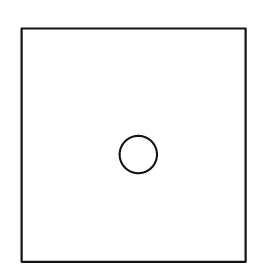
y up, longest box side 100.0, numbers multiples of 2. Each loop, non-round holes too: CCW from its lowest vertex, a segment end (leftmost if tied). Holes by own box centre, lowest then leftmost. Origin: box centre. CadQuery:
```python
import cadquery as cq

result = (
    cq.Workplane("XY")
    .moveTo(-48.0, -50.0)
    .lineTo(48.0, -50.0)
    .lineTo(48.0, 50.0)
    .lineTo(-48.0, 50.0)
    .close()
    .moveTo(2.0, -4.0)
    .circle(8.0)
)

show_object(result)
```